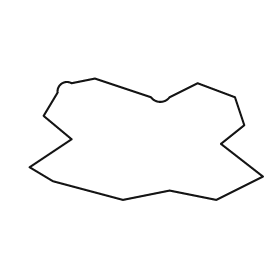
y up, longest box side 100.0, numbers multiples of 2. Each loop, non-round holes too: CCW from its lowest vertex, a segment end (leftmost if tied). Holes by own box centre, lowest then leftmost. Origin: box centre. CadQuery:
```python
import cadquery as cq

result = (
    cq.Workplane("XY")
    .moveTo(-10.0, -26.0)
    .lineTo(10.0, -22.0)
    .lineTo(30.0, -26.0)
    .lineTo(50.0, -16.0)
    .lineTo(32.0, -2.0)
    .lineTo(42.0, 6.0)
    .lineTo(38.0, 18.0)
    .lineTo(22.0, 24.0)
    .lineTo(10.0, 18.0)
    .threePointArc((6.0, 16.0), (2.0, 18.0))
    .lineTo(-22.0, 26.0)
    .lineTo(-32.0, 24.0)
    .threePointArc((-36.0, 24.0), (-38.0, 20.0))
    .lineTo(-44.0, 10.0)
    .lineTo(-32.0, 0.0)
    .lineTo(-50.0, -12.0)
    .lineTo(-40.0, -18.0)
    .close()
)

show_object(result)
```